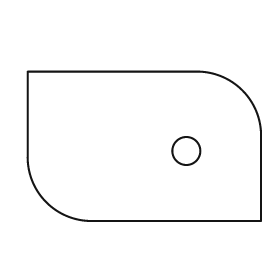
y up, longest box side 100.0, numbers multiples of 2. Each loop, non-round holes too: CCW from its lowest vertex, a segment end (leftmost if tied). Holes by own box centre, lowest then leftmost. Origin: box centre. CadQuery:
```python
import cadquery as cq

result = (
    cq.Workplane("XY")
    .moveTo(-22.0, -32.0)
    .lineTo(50.0, -32.0)
    .lineTo(50.0, 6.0)
    .threePointArc((42.0, 24.0), (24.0, 32.0))
    .lineTo(-50.0, 32.0)
    .lineTo(-50.0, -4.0)
    .threePointArc((-42.0, -24.0), (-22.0, -32.0))
    .close()
    .moveTo(18.0, -2.0)
    .circle(6.0)
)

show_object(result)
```